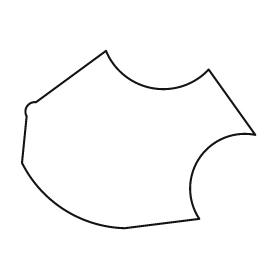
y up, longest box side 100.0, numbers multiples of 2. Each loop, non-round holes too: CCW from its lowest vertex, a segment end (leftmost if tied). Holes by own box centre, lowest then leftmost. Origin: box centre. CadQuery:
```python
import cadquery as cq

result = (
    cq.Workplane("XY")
    .moveTo(-6.0, -38.0)
    .lineTo(26.0, -34.0)
    .threePointArc((26.0, -8.0), (50.0, 2.0))
    .lineTo(30.0, 30.0)
    .threePointArc((6.0, 22.0), (-14.0, 38.0))
    .lineTo(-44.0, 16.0)
    .threePointArc((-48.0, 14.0), (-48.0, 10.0))
    .lineTo(-50.0, -10.0)
    .threePointArc((-32.0, -30.0), (-6.0, -38.0))
    .close()
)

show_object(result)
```